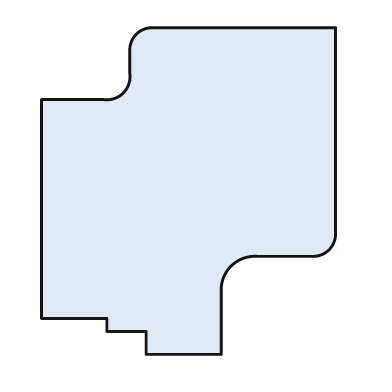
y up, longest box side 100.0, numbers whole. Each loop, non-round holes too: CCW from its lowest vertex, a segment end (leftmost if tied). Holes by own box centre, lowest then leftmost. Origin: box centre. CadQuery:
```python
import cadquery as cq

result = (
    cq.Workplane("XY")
    .moveTo(-13.0, -50.0)
    .lineTo(10.0, -50.0)
    .lineTo(10.0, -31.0)
    .threePointArc((13.0, -23.0), (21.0, -20.0))
    .lineTo(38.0, -20.0)
    .threePointArc((43.0, -18.0), (45.0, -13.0))
    .lineTo(45.0, 50.0)
    .lineTo(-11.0, 50.0)
    .threePointArc((-16.0, 48.0), (-18.0, 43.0))
    .lineTo(-18.0, 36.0)
    .threePointArc((-20.0, 30.0), (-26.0, 28.0))
    .lineTo(-45.0, 28.0)
    .lineTo(-45.0, -39.0)
    .lineTo(-25.0, -39.0)
    .lineTo(-25.0, -43.0)
    .lineTo(-13.0, -43.0)
    .close()
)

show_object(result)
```